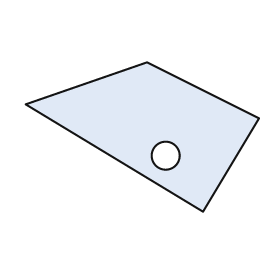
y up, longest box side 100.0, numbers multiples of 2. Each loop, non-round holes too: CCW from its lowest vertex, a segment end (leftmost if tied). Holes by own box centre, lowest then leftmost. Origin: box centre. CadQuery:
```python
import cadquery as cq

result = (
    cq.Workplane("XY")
    .moveTo(26.0, -32.0)
    .lineTo(50.0, 8.0)
    .lineTo(2.0, 32.0)
    .lineTo(-50.0, 14.0)
    .close()
    .moveTo(10.0, -8.0)
    .circle(6.0)
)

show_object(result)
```